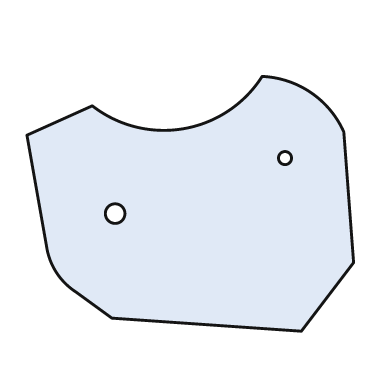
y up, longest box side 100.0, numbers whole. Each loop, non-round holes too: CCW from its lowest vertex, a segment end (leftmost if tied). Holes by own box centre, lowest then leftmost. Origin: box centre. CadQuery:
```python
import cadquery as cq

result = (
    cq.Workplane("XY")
    .moveTo(34.0, -39.0)
    .lineTo(50.0, -18.0)
    .lineTo(47.0, 22.0)
    .threePointArc((37.0, 34.0), (22.0, 39.0))
    .threePointArc((-2.0, 23.0), (-30.0, 30.0))
    .lineTo(-50.0, 21.0)
    .lineTo(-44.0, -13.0)
    .threePointArc((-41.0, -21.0), (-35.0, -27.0))
    .lineTo(-24.0, -35.0)
    .close()
    .moveTo(-23.0, -3.0)
    .circle(3.0)
    .moveTo(29.0, 14.0)
    .circle(2.0)
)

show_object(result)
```